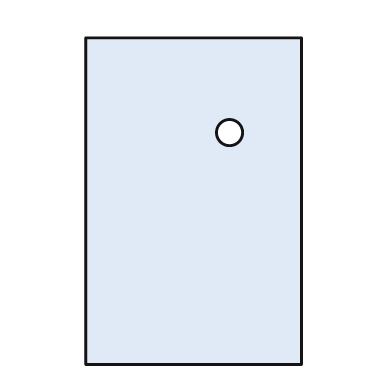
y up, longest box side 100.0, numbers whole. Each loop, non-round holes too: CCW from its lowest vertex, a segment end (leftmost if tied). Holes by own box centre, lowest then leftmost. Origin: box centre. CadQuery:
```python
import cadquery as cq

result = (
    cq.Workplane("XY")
    .moveTo(-33.0, -50.0)
    .lineTo(33.0, -50.0)
    .lineTo(33.0, 50.0)
    .lineTo(-33.0, 50.0)
    .close()
    .moveTo(11.0, 21.0)
    .circle(4.0)
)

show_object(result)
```